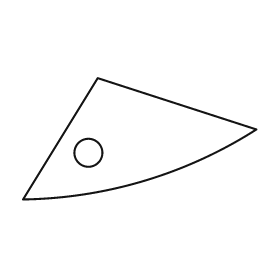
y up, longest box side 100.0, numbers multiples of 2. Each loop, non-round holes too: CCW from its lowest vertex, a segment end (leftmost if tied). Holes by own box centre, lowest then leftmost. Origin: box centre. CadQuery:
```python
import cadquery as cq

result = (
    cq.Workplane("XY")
    .moveTo(-50.0, -26.0)
    .threePointArc((2.0, -18.0), (50.0, 4.0))
    .lineTo(-18.0, 26.0)
    .close()
    .moveTo(-22.0, -6.0)
    .circle(6.0)
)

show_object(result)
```